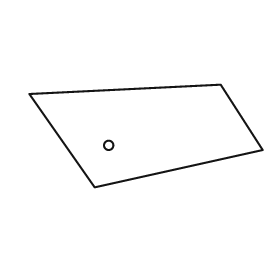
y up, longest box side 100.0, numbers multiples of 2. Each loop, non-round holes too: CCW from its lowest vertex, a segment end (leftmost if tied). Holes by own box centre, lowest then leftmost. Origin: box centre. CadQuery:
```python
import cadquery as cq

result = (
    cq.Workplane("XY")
    .moveTo(-22.0, -22.0)
    .lineTo(50.0, -6.0)
    .lineTo(32.0, 22.0)
    .lineTo(-50.0, 18.0)
    .close()
    .moveTo(-16.0, -4.0)
    .circle(2.0)
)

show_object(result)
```